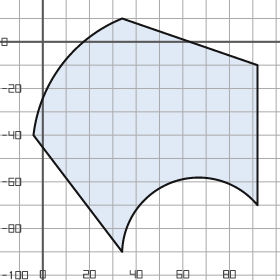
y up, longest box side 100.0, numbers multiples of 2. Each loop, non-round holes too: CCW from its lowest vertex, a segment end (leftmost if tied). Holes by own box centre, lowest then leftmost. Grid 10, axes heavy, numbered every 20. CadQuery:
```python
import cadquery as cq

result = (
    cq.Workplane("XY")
    .moveTo(34.0, -90.0)
    .threePointArc((56.0, -60.0), (92.0, -70.0))
    .lineTo(92.0, -10.0)
    .lineTo(34.0, 10.0)
    .threePointArc((8.0, -10.0), (-4.0, -40.0))
    .close()
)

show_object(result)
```